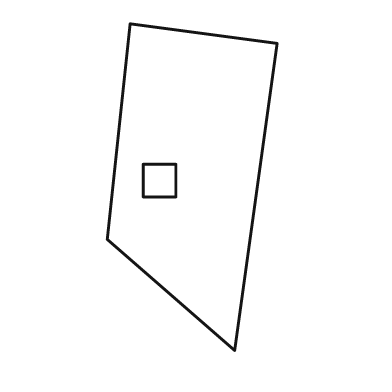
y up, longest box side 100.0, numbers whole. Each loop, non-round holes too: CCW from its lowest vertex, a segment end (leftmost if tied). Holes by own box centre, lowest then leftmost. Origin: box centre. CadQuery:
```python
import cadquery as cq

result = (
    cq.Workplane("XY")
    .moveTo(13.0, -50.0)
    .lineTo(26.0, 44.0)
    .lineTo(-19.0, 50.0)
    .lineTo(-26.0, -16.0)
    .close()
    .moveTo(-15.0, -3.0)
    .lineTo(-5.0, -3.0)
    .lineTo(-5.0, 7.0)
    .lineTo(-15.0, 7.0)
    .close()
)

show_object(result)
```